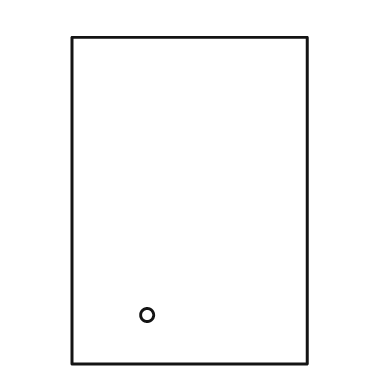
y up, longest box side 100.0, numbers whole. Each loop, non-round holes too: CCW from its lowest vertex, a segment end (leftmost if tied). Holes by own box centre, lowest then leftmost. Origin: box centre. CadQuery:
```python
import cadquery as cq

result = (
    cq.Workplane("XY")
    .moveTo(-36.0, -50.0)
    .lineTo(36.0, -50.0)
    .lineTo(36.0, 50.0)
    .lineTo(-36.0, 50.0)
    .close()
    .moveTo(-13.0, -35.0)
    .circle(2.0)
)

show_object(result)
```